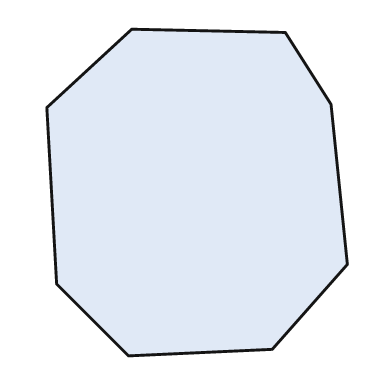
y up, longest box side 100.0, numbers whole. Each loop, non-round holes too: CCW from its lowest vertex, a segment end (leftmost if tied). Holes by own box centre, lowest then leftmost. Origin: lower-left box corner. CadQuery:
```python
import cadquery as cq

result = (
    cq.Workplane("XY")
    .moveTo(25.0, 0.0)
    .lineTo(69.0, 2.0)
    .lineTo(92.0, 28.0)
    .lineTo(87.0, 77.0)
    .lineTo(73.0, 99.0)
    .lineTo(26.0, 100.0)
    .lineTo(0.0, 76.0)
    .lineTo(3.0, 22.0)
    .close()
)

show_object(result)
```